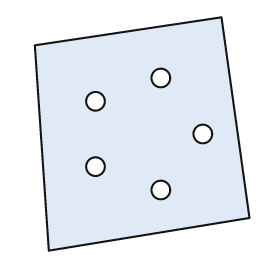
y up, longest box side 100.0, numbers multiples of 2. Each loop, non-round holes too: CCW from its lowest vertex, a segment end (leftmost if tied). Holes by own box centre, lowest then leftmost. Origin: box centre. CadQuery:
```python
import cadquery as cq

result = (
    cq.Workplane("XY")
    .moveTo(-40.0, -50.0)
    .lineTo(46.0, -36.0)
    .lineTo(34.0, 50.0)
    .lineTo(-46.0, 38.0)
    .close()
    .moveTo(8.0, -24.0)
    .circle(4.0)
    .moveTo(-20.0, -14.0)
    .circle(4.0)
    .moveTo(26.0, 0.0)
    .circle(4.0)
    .moveTo(-20.0, 14.0)
    .circle(4.0)
    .moveTo(8.0, 24.0)
    .circle(4.0)
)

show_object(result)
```